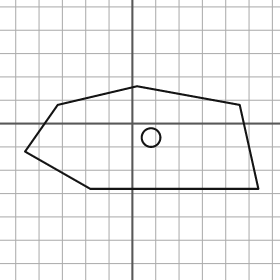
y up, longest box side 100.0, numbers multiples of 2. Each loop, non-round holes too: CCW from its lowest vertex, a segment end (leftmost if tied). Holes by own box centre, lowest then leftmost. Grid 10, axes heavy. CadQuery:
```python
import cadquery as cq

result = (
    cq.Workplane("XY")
    .moveTo(-18.0, -28.0)
    .lineTo(54.0, -28.0)
    .lineTo(46.0, 8.0)
    .lineTo(2.0, 16.0)
    .lineTo(-32.0, 8.0)
    .lineTo(-46.0, -12.0)
    .close()
    .moveTo(8.0, -6.0)
    .circle(4.0)
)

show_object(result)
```